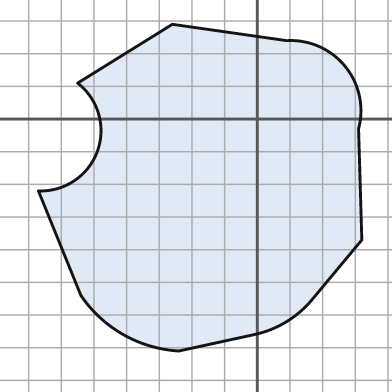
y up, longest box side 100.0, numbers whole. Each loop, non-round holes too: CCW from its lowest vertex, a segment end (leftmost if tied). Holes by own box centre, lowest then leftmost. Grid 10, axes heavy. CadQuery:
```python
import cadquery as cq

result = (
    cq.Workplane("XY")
    .moveTo(-24.0, -71.0)
    .lineTo(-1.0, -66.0)
    .threePointArc((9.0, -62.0), (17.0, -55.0))
    .lineTo(32.0, -37.0)
    .lineTo(31.0, -3.0)
    .threePointArc((27.0, 16.0), (9.0, 24.0))
    .lineTo(-26.0, 29.0)
    .lineTo(-55.0, 11.0)
    .threePointArc((-49.0, -10.0), (-67.0, -22.0))
    .lineTo(-54.0, -54.0)
    .threePointArc((-41.0, -66.0), (-24.0, -71.0))
    .close()
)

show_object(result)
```